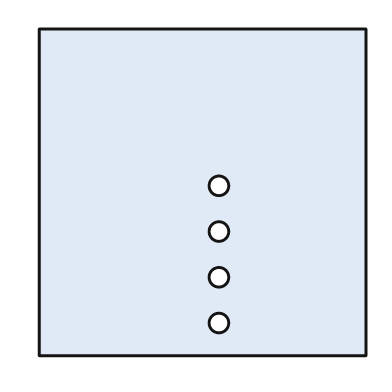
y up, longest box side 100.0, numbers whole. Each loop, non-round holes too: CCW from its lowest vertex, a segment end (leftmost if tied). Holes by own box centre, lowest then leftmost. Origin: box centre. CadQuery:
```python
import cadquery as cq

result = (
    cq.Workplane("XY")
    .moveTo(-50.0, -50.0)
    .lineTo(50.0, -50.0)
    .lineTo(50.0, 50.0)
    .lineTo(-50.0, 50.0)
    .close()
    .moveTo(5.0, -40.0)
    .circle(3.0)
    .moveTo(5.0, -26.0)
    .circle(3.0)
    .moveTo(5.0, -12.0)
    .circle(3.0)
    .moveTo(5.0, 2.0)
    .circle(3.0)
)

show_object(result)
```